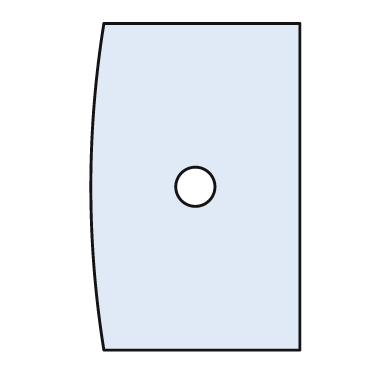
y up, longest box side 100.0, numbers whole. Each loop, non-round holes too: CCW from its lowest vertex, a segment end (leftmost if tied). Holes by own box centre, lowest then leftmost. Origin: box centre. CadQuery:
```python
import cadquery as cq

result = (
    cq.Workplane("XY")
    .moveTo(-28.0, -50.0)
    .lineTo(32.0, -50.0)
    .lineTo(32.0, 50.0)
    .lineTo(-28.0, 50.0)
    .threePointArc((-32.0, 0.0), (-28.0, -50.0))
    .close()
    .moveTo(0.0, 0.0)
    .circle(6.0)
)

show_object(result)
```